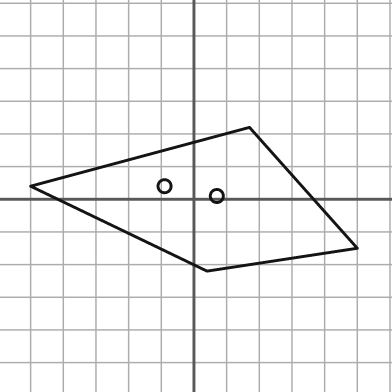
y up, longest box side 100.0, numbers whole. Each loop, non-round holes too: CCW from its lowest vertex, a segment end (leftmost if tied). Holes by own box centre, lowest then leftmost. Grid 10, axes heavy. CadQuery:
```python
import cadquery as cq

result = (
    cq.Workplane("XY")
    .moveTo(4.0, -22.0)
    .lineTo(50.0, -15.0)
    .lineTo(17.0, 22.0)
    .lineTo(-50.0, 4.0)
    .close()
    .moveTo(7.0, 1.0)
    .circle(2.0)
    .moveTo(-9.0, 4.0)
    .circle(2.0)
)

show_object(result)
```